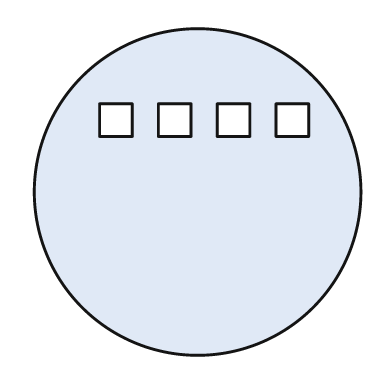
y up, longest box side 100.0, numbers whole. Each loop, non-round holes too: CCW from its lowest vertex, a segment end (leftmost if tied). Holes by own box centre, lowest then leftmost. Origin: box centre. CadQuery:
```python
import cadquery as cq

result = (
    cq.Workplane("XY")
    .moveTo(0.0, 0.0)
    .circle(50.0)
    .moveTo(-30.0, 17.0)
    .lineTo(-20.0, 17.0)
    .lineTo(-20.0, 27.0)
    .lineTo(-30.0, 27.0)
    .close()
    .moveTo(-12.0, 17.0)
    .lineTo(-2.0, 17.0)
    .lineTo(-2.0, 27.0)
    .lineTo(-12.0, 27.0)
    .close()
    .moveTo(6.0, 17.0)
    .lineTo(16.0, 17.0)
    .lineTo(16.0, 27.0)
    .lineTo(6.0, 27.0)
    .close()
    .moveTo(24.0, 17.0)
    .lineTo(34.0, 17.0)
    .lineTo(34.0, 27.0)
    .lineTo(24.0, 27.0)
    .close()
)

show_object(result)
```